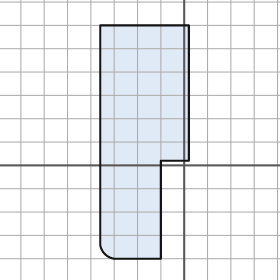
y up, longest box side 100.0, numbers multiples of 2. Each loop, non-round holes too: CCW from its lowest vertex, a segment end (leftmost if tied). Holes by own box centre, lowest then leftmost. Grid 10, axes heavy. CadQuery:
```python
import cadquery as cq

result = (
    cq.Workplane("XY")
    .moveTo(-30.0, -40.0)
    .lineTo(-10.0, -40.0)
    .lineTo(-10.0, 2.0)
    .lineTo(2.0, 2.0)
    .lineTo(2.0, 60.0)
    .lineTo(-36.0, 60.0)
    .lineTo(-36.0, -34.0)
    .threePointArc((-34.0, -38.0), (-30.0, -40.0))
    .close()
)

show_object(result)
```